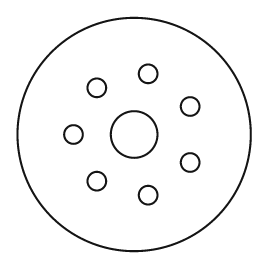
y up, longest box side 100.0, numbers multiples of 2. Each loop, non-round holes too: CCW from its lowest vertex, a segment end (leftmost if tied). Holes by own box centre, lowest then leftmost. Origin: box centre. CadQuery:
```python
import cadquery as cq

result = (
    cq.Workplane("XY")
    .moveTo(0.0, 0.0)
    .circle(50.0)
    .moveTo(6.0, -26.0)
    .circle(4.0)
    .moveTo(-16.0, -20.0)
    .circle(4.0)
    .moveTo(24.0, -12.0)
    .circle(4.0)
    .moveTo(-26.0, 0.0)
    .circle(4.0)
    .moveTo(0.0, 0.0)
    .circle(10.0)
    .moveTo(24.0, 12.0)
    .circle(4.0)
    .moveTo(-16.0, 20.0)
    .circle(4.0)
    .moveTo(6.0, 26.0)
    .circle(4.0)
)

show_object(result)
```